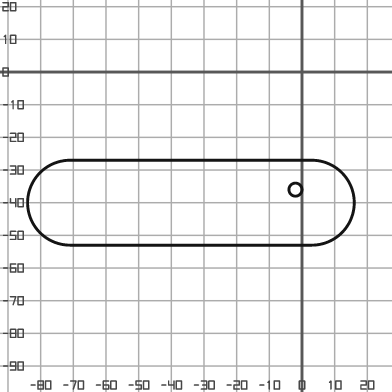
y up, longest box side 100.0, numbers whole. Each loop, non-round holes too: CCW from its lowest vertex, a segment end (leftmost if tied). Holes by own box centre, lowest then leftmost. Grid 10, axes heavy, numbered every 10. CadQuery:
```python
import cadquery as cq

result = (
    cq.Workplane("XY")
    .moveTo(-71.0, -53.0)
    .lineTo(3.0, -53.0)
    .threePointArc((16.0, -40.0), (3.0, -27.0))
    .lineTo(-71.0, -27.0)
    .threePointArc((-84.0, -40.0), (-71.0, -53.0))
    .close()
    .moveTo(-2.0, -36.0)
    .circle(2.0)
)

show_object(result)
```